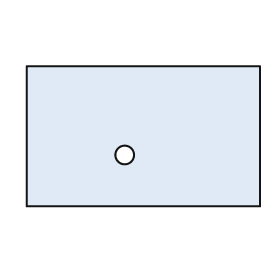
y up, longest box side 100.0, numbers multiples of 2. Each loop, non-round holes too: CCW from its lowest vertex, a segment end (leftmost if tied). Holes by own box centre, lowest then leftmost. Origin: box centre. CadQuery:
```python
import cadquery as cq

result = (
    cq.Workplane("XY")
    .moveTo(-50.0, -30.0)
    .lineTo(50.0, -30.0)
    .lineTo(50.0, 30.0)
    .lineTo(-50.0, 30.0)
    .close()
    .moveTo(-8.0, -8.0)
    .circle(4.0)
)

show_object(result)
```